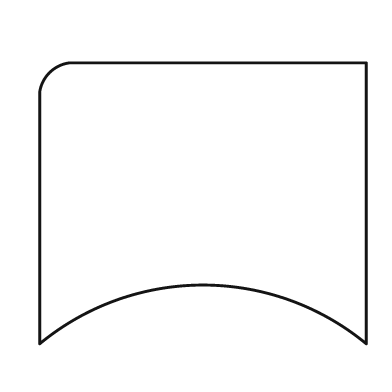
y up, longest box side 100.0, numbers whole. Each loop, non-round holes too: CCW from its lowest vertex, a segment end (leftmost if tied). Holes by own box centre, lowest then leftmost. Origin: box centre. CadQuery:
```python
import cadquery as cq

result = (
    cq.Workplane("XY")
    .moveTo(-50.0, -43.0)
    .threePointArc((0.0, -25.0), (50.0, -43.0))
    .lineTo(50.0, 43.0)
    .lineTo(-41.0, 43.0)
    .threePointArc((-47.0, 40.0), (-50.0, 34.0))
    .close()
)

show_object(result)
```